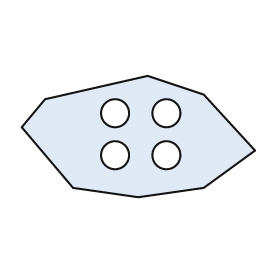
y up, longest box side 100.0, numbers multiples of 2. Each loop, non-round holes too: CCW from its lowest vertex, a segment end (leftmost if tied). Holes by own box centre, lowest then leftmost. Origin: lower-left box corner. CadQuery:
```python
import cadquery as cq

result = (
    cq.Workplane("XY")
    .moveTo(50.0, 0.0)
    .lineTo(78.0, 4.0)
    .lineTo(100.0, 20.0)
    .lineTo(78.0, 44.0)
    .lineTo(54.0, 52.0)
    .lineTo(10.0, 42.0)
    .lineTo(0.0, 30.0)
    .lineTo(22.0, 4.0)
    .close()
    .moveTo(40.0, 18.0)
    .circle(6.0)
    .moveTo(62.0, 18.0)
    .circle(6.0)
    .moveTo(40.0, 36.0)
    .circle(6.0)
    .moveTo(62.0, 36.0)
    .circle(6.0)
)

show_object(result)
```